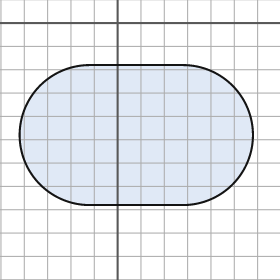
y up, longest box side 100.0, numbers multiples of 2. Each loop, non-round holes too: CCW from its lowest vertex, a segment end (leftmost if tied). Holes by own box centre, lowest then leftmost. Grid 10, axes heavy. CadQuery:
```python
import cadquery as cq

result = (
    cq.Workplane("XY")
    .moveTo(-12.0, -78.0)
    .lineTo(28.0, -78.0)
    .threePointArc((58.0, -48.0), (28.0, -18.0))
    .lineTo(-12.0, -18.0)
    .threePointArc((-42.0, -48.0), (-12.0, -78.0))
    .close()
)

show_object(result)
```